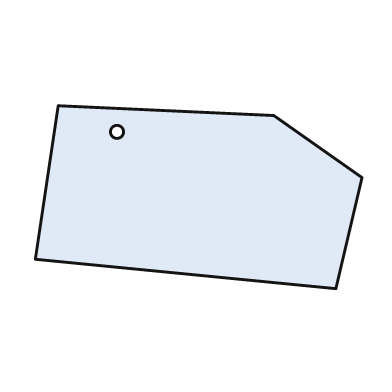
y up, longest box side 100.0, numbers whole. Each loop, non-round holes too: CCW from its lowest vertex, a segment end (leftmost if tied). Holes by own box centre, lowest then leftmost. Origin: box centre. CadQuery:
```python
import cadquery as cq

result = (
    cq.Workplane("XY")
    .moveTo(42.0, -28.0)
    .lineTo(50.0, 6.0)
    .lineTo(23.0, 25.0)
    .lineTo(-43.0, 28.0)
    .lineTo(-50.0, -19.0)
    .close()
    .moveTo(-25.0, 20.0)
    .circle(2.0)
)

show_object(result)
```